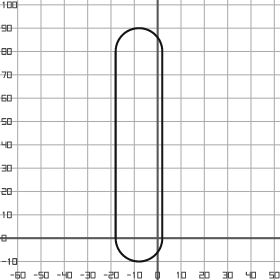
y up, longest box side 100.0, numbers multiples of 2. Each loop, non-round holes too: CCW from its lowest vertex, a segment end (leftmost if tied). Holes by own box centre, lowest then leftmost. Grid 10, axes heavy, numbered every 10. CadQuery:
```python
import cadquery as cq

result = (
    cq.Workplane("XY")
    .moveTo(-18.0, 0.0)
    .threePointArc((-8.0, -10.0), (2.0, 0.0))
    .lineTo(2.0, 80.0)
    .threePointArc((-8.0, 90.0), (-18.0, 80.0))
    .close()
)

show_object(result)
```